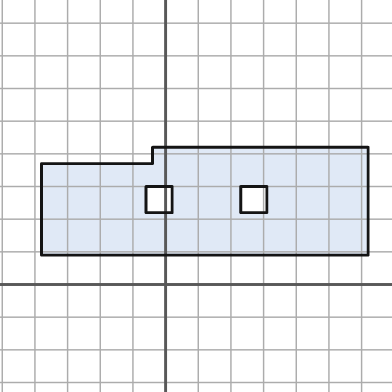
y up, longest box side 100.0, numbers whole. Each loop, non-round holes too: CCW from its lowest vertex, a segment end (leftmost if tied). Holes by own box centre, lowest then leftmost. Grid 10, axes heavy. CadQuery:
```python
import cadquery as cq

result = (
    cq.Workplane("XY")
    .moveTo(-38.0, 9.0)
    .lineTo(62.0, 9.0)
    .lineTo(62.0, 42.0)
    .lineTo(-4.0, 42.0)
    .lineTo(-4.0, 37.0)
    .lineTo(-38.0, 37.0)
    .close()
    .moveTo(-6.0, 22.0)
    .lineTo(2.0, 22.0)
    .lineTo(2.0, 30.0)
    .lineTo(-6.0, 30.0)
    .close()
    .moveTo(23.0, 22.0)
    .lineTo(31.0, 22.0)
    .lineTo(31.0, 30.0)
    .lineTo(23.0, 30.0)
    .close()
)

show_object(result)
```